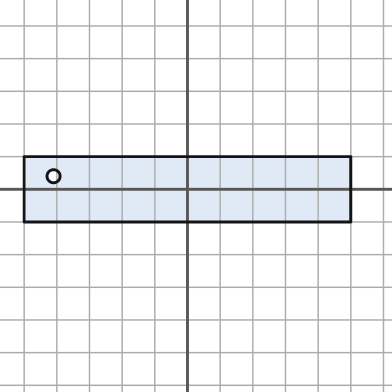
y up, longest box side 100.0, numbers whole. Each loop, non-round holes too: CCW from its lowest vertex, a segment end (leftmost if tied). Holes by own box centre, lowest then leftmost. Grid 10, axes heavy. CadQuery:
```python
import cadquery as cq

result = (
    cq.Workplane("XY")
    .moveTo(-50.0, -10.0)
    .lineTo(50.0, -10.0)
    .lineTo(50.0, 10.0)
    .lineTo(-50.0, 10.0)
    .close()
    .moveTo(-41.0, 4.0)
    .circle(2.0)
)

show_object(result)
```